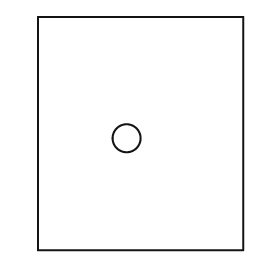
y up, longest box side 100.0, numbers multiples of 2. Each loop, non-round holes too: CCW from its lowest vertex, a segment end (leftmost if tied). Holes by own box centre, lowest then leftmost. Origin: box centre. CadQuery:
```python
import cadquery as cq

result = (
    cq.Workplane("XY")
    .moveTo(-44.0, -50.0)
    .lineTo(44.0, -50.0)
    .lineTo(44.0, 50.0)
    .lineTo(-44.0, 50.0)
    .close()
    .moveTo(-6.0, -2.0)
    .circle(6.0)
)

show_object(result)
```